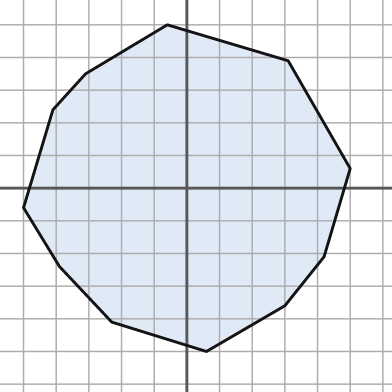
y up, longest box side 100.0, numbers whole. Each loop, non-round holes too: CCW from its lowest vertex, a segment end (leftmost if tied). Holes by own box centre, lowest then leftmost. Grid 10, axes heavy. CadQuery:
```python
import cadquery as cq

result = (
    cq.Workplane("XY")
    .moveTo(6.0, -50.0)
    .lineTo(30.0, -36.0)
    .lineTo(42.0, -21.0)
    .lineTo(50.0, 6.0)
    .lineTo(31.0, 39.0)
    .lineTo(-6.0, 50.0)
    .lineTo(-31.0, 35.0)
    .lineTo(-41.0, 24.0)
    .lineTo(-50.0, -6.0)
    .lineTo(-39.0, -24.0)
    .lineTo(-23.0, -41.0)
    .close()
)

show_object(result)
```